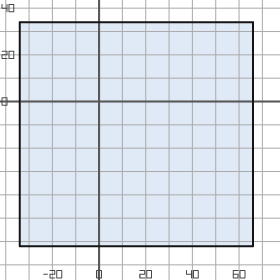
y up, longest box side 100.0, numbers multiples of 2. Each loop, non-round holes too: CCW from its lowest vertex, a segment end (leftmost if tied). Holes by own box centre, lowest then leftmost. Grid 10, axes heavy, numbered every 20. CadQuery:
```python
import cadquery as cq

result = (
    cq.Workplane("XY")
    .moveTo(-34.0, -62.0)
    .lineTo(66.0, -62.0)
    .lineTo(66.0, 34.0)
    .lineTo(-34.0, 34.0)
    .close()
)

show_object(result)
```